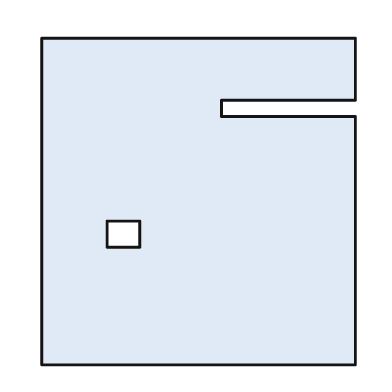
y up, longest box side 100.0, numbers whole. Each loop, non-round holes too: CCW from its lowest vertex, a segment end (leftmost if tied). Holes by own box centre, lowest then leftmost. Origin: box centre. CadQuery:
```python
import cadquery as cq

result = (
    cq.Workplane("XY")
    .moveTo(-48.0, -50.0)
    .lineTo(48.0, -50.0)
    .lineTo(48.0, 26.0)
    .lineTo(7.0, 26.0)
    .lineTo(7.0, 31.0)
    .lineTo(48.0, 31.0)
    .lineTo(48.0, 50.0)
    .lineTo(-48.0, 50.0)
    .close()
    .moveTo(-28.0, -14.0)
    .lineTo(-18.0, -14.0)
    .lineTo(-18.0, -6.0)
    .lineTo(-28.0, -6.0)
    .close()
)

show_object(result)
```